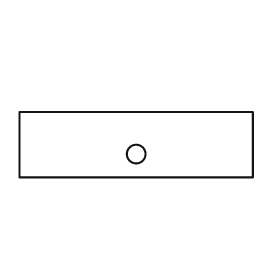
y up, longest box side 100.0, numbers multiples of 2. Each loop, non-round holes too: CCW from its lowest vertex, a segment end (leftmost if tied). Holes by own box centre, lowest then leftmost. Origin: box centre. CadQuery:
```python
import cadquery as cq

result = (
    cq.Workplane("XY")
    .moveTo(-50.0, -14.0)
    .lineTo(50.0, -14.0)
    .lineTo(50.0, 14.0)
    .lineTo(-50.0, 14.0)
    .close()
    .moveTo(0.0, -4.0)
    .circle(4.0)
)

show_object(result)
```